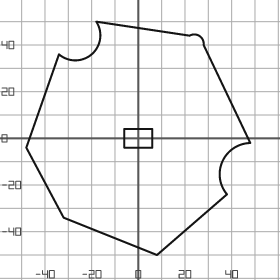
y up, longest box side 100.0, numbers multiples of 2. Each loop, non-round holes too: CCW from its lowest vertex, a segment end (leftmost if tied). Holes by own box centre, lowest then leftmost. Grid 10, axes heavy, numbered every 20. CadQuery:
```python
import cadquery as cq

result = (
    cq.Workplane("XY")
    .moveTo(8.0, -50.0)
    .lineTo(38.0, -24.0)
    .threePointArc((36.0, -10.0), (48.0, -2.0))
    .lineTo(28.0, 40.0)
    .threePointArc((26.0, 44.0), (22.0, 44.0))
    .lineTo(-18.0, 50.0)
    .threePointArc((-20.0, 36.0), (-34.0, 36.0))
    .lineTo(-48.0, -4.0)
    .lineTo(-32.0, -34.0)
    .close()
    .moveTo(-6.0, -4.0)
    .lineTo(6.0, -4.0)
    .lineTo(6.0, 4.0)
    .lineTo(-6.0, 4.0)
    .close()
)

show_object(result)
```